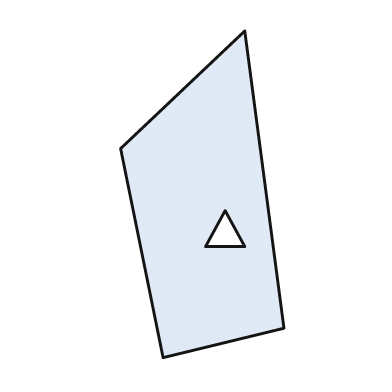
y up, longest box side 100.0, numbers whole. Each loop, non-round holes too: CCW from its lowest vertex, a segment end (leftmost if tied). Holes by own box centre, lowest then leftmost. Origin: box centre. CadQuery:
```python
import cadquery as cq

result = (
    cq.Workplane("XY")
    .moveTo(-12.0, -50.0)
    .lineTo(25.0, -41.0)
    .lineTo(13.0, 50.0)
    .lineTo(-25.0, 14.0)
    .close()
    .moveTo(1.0, -16.0)
    .lineTo(13.0, -16.0)
    .lineTo(7.0, -5.0)
    .close()
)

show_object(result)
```